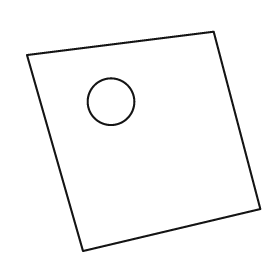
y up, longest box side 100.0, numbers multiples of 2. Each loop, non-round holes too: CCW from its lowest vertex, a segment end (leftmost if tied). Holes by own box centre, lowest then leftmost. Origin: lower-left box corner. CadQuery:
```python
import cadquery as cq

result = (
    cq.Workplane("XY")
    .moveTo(24.0, 0.0)
    .lineTo(100.0, 18.0)
    .lineTo(80.0, 94.0)
    .lineTo(0.0, 84.0)
    .close()
    .moveTo(36.0, 64.0)
    .circle(10.0)
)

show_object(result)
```